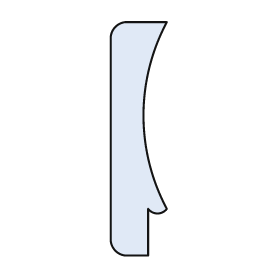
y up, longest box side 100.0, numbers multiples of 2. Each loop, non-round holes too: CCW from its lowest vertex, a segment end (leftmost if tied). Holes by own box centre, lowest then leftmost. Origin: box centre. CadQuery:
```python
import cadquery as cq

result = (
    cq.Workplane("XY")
    .moveTo(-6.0, -50.0)
    .lineTo(4.0, -50.0)
    .lineTo(4.0, -30.0)
    .threePointArc((8.0, -32.0), (12.0, -30.0))
    .threePointArc((2.0, 10.0), (12.0, 50.0))
    .lineTo(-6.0, 50.0)
    .threePointArc((-10.0, 48.0), (-12.0, 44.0))
    .lineTo(-12.0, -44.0)
    .threePointArc((-10.0, -48.0), (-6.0, -50.0))
    .close()
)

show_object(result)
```